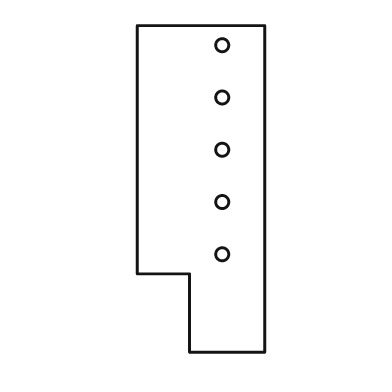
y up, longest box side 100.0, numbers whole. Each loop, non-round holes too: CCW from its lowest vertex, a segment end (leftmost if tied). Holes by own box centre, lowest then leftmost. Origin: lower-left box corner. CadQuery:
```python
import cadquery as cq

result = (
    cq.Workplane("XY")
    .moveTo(16.0, 0.0)
    .lineTo(39.0, 0.0)
    .lineTo(39.0, 100.0)
    .lineTo(0.0, 100.0)
    .lineTo(0.0, 24.0)
    .lineTo(16.0, 24.0)
    .close()
    .moveTo(26.0, 30.0)
    .circle(2.0)
    .moveTo(26.0, 46.0)
    .circle(2.0)
    .moveTo(26.0, 62.0)
    .circle(2.0)
    .moveTo(26.0, 78.0)
    .circle(2.0)
    .moveTo(26.0, 94.0)
    .circle(2.0)
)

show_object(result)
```